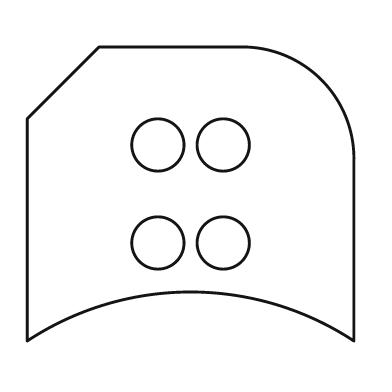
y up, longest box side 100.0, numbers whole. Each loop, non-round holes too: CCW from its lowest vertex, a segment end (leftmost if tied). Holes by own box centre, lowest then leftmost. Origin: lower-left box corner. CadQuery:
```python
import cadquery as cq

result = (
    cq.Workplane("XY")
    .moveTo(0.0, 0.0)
    .threePointArc((50.0, 15.0), (100.0, 0.0))
    .lineTo(100.0, 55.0)
    .threePointArc((90.0, 80.0), (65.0, 90.0))
    .lineTo(22.0, 90.0)
    .lineTo(0.0, 68.0)
    .close()
    .moveTo(40.0, 30.0)
    .circle(8.0)
    .moveTo(60.0, 30.0)
    .circle(8.0)
    .moveTo(40.0, 60.0)
    .circle(8.0)
    .moveTo(60.0, 60.0)
    .circle(8.0)
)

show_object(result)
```